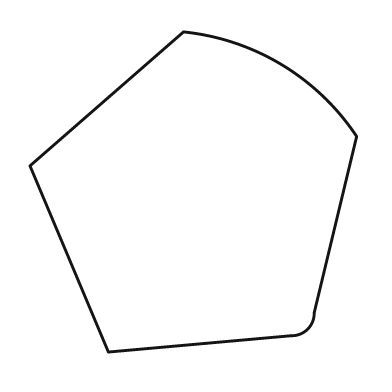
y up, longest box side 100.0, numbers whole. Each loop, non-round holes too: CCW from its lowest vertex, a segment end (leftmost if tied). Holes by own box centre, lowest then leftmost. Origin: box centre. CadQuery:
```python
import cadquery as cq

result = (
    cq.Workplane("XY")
    .moveTo(-26.0, -49.0)
    .lineTo(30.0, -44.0)
    .threePointArc((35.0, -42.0), (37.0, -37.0))
    .lineTo(50.0, 17.0)
    .threePointArc((27.0, 39.0), (-3.0, 49.0))
    .lineTo(-50.0, 8.0)
    .close()
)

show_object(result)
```